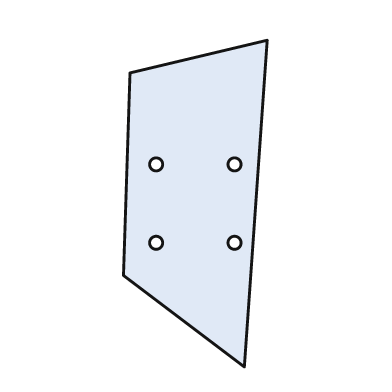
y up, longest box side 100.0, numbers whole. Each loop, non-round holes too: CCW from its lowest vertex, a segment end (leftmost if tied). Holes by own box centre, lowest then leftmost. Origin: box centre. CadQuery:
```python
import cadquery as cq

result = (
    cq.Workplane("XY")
    .moveTo(15.0, -50.0)
    .lineTo(22.0, 50.0)
    .lineTo(-20.0, 40.0)
    .lineTo(-22.0, -22.0)
    .close()
    .moveTo(-12.0, -12.0)
    .circle(2.0)
    .moveTo(12.0, -12.0)
    .circle(2.0)
    .moveTo(-12.0, 12.0)
    .circle(2.0)
    .moveTo(12.0, 12.0)
    .circle(2.0)
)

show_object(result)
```